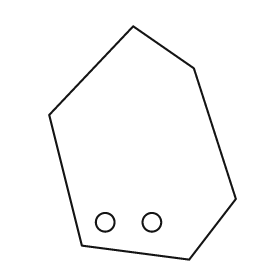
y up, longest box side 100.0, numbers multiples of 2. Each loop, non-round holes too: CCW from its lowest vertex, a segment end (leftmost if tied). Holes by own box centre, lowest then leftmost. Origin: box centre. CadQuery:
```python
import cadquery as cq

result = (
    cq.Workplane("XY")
    .moveTo(20.0, -50.0)
    .lineTo(40.0, -24.0)
    .lineTo(22.0, 32.0)
    .lineTo(-4.0, 50.0)
    .lineTo(-40.0, 12.0)
    .lineTo(-26.0, -44.0)
    .close()
    .moveTo(-16.0, -34.0)
    .circle(4.0)
    .moveTo(4.0, -34.0)
    .circle(4.0)
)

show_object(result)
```